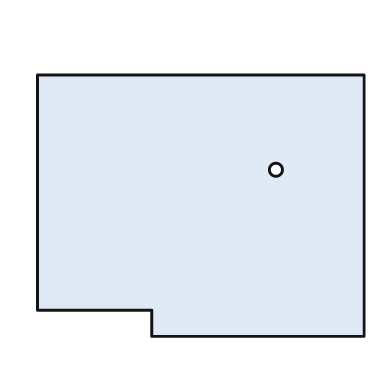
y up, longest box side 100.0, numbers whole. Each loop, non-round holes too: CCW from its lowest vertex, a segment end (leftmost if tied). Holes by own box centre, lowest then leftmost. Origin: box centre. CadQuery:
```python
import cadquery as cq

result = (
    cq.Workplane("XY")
    .moveTo(-15.0, -40.0)
    .lineTo(50.0, -40.0)
    .lineTo(50.0, 40.0)
    .lineTo(-50.0, 40.0)
    .lineTo(-50.0, -32.0)
    .lineTo(-15.0, -32.0)
    .close()
    .moveTo(23.0, 11.0)
    .circle(2.0)
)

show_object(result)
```